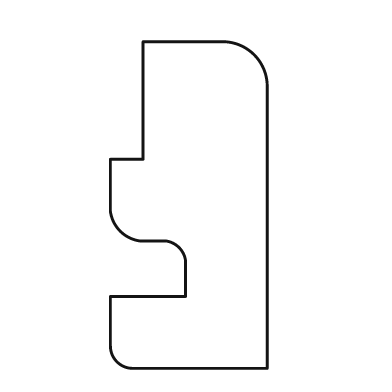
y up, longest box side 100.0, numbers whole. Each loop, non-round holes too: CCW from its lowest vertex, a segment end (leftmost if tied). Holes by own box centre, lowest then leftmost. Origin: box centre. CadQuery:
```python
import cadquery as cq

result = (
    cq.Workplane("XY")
    .moveTo(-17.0, -50.0)
    .lineTo(24.0, -50.0)
    .lineTo(24.0, 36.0)
    .threePointArc((20.0, 46.0), (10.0, 50.0))
    .lineTo(-14.0, 50.0)
    .lineTo(-14.0, 14.0)
    .lineTo(-24.0, 14.0)
    .lineTo(-24.0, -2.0)
    .threePointArc((-21.0, -8.0), (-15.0, -11.0))
    .lineTo(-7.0, -11.0)
    .threePointArc((-3.0, -13.0), (-1.0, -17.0))
    .lineTo(-1.0, -28.0)
    .lineTo(-24.0, -28.0)
    .lineTo(-24.0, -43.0)
    .threePointArc((-22.0, -48.0), (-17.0, -50.0))
    .close()
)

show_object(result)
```